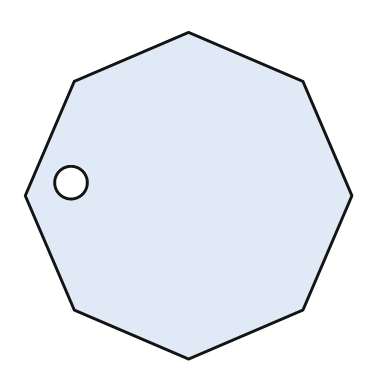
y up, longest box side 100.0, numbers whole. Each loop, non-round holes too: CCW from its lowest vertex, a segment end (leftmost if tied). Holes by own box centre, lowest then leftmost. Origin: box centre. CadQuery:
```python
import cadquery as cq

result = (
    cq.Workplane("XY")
    .moveTo(0.0, -50.0)
    .lineTo(35.0, -35.0)
    .lineTo(50.0, 0.0)
    .lineTo(35.0, 35.0)
    .lineTo(0.0, 50.0)
    .lineTo(-35.0, 35.0)
    .lineTo(-50.0, 0.0)
    .lineTo(-35.0, -35.0)
    .close()
    .moveTo(-36.0, 4.0)
    .circle(5.0)
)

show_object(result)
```